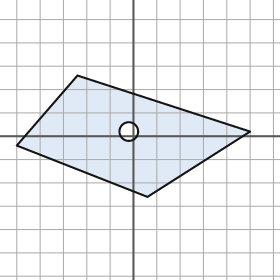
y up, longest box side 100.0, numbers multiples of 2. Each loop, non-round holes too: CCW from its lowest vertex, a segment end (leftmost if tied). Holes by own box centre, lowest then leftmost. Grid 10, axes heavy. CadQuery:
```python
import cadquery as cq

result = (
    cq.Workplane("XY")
    .moveTo(6.0, -26.0)
    .lineTo(50.0, 2.0)
    .lineTo(-24.0, 26.0)
    .lineTo(-50.0, -4.0)
    .close()
    .moveTo(-2.0, 2.0)
    .circle(4.0)
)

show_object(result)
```